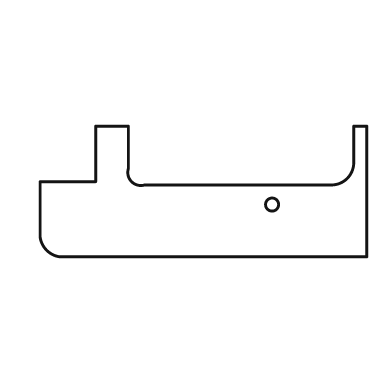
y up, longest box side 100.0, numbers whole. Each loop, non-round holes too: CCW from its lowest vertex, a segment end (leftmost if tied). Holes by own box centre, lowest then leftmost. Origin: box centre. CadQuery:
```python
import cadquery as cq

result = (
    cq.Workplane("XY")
    .moveTo(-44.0, -20.0)
    .lineTo(50.0, -20.0)
    .lineTo(50.0, 20.0)
    .lineTo(46.0, 20.0)
    .lineTo(46.0, 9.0)
    .threePointArc((44.0, 4.0), (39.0, 2.0))
    .lineTo(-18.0, 2.0)
    .threePointArc((-22.0, 3.0), (-23.0, 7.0))
    .lineTo(-23.0, 20.0)
    .lineTo(-33.0, 20.0)
    .lineTo(-33.0, 3.0)
    .lineTo(-50.0, 3.0)
    .lineTo(-50.0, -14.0)
    .threePointArc((-48.0, -18.0), (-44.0, -20.0))
    .close()
    .moveTo(21.0, -4.0)
    .circle(2.0)
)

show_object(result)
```